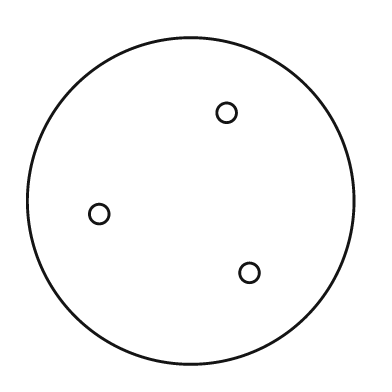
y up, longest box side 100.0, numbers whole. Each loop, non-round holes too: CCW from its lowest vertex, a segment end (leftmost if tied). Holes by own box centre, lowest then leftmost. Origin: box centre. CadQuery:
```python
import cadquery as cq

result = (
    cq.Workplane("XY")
    .moveTo(0.0, 0.0)
    .circle(50.0)
    .moveTo(18.0, -22.0)
    .circle(3.0)
    .moveTo(-28.0, -4.0)
    .circle(3.0)
    .moveTo(11.0, 27.0)
    .circle(3.0)
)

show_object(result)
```